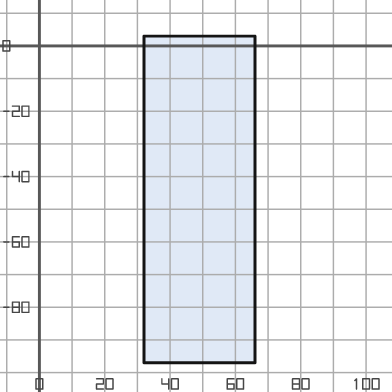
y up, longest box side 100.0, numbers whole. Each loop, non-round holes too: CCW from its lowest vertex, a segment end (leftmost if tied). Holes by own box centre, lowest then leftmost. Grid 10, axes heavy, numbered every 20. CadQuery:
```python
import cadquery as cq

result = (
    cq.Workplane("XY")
    .moveTo(32.0, -97.0)
    .lineTo(66.0, -97.0)
    .lineTo(66.0, 3.0)
    .lineTo(32.0, 3.0)
    .close()
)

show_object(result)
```